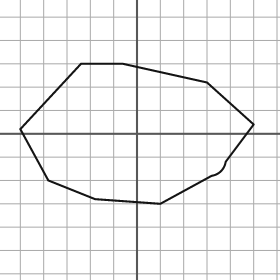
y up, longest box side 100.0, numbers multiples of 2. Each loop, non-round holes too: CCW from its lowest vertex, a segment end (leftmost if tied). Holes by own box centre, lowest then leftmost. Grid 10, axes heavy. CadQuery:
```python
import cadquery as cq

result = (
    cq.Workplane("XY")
    .moveTo(10.0, -30.0)
    .lineTo(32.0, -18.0)
    .threePointArc((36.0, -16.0), (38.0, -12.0))
    .lineTo(50.0, 4.0)
    .lineTo(30.0, 22.0)
    .lineTo(-6.0, 30.0)
    .lineTo(-24.0, 30.0)
    .lineTo(-50.0, 2.0)
    .lineTo(-38.0, -20.0)
    .lineTo(-18.0, -28.0)
    .close()
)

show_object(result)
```